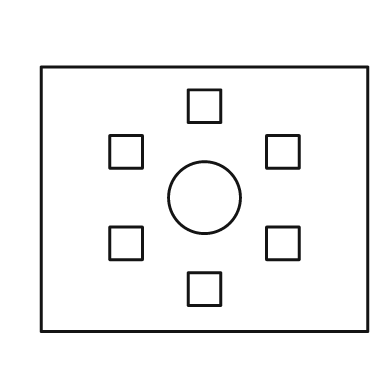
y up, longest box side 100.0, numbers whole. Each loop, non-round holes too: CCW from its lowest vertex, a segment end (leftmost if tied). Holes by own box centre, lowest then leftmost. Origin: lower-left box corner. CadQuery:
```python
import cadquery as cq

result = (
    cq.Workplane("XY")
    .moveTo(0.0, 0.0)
    .lineTo(100.0, 0.0)
    .lineTo(100.0, 81.0)
    .lineTo(0.0, 81.0)
    .close()
    .moveTo(45.0, 8.0)
    .lineTo(55.0, 8.0)
    .lineTo(55.0, 18.0)
    .lineTo(45.0, 18.0)
    .close()
    .moveTo(21.0, 22.0)
    .lineTo(31.0, 22.0)
    .lineTo(31.0, 32.0)
    .lineTo(21.0, 32.0)
    .close()
    .moveTo(69.0, 22.0)
    .lineTo(79.0, 22.0)
    .lineTo(79.0, 32.0)
    .lineTo(69.0, 32.0)
    .close()
    .moveTo(50.0, 41.0)
    .circle(11.0)
    .moveTo(21.0, 50.0)
    .lineTo(31.0, 50.0)
    .lineTo(31.0, 60.0)
    .lineTo(21.0, 60.0)
    .close()
    .moveTo(69.0, 50.0)
    .lineTo(79.0, 50.0)
    .lineTo(79.0, 60.0)
    .lineTo(69.0, 60.0)
    .close()
    .moveTo(45.0, 64.0)
    .lineTo(55.0, 64.0)
    .lineTo(55.0, 74.0)
    .lineTo(45.0, 74.0)
    .close()
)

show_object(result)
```